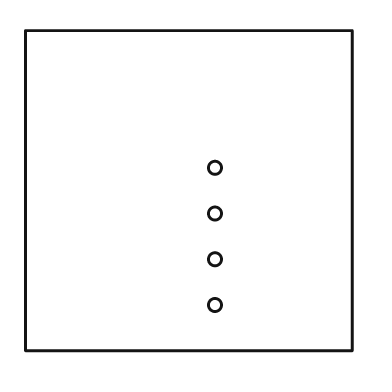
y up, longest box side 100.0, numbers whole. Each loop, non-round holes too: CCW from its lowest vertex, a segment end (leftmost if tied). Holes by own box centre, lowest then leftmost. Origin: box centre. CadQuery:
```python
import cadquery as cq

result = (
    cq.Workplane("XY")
    .moveTo(-50.0, -49.0)
    .lineTo(50.0, -49.0)
    .lineTo(50.0, 49.0)
    .lineTo(-50.0, 49.0)
    .close()
    .moveTo(8.0, -35.0)
    .circle(2.0)
    .moveTo(8.0, -21.0)
    .circle(2.0)
    .moveTo(8.0, -7.0)
    .circle(2.0)
    .moveTo(8.0, 7.0)
    .circle(2.0)
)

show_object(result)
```